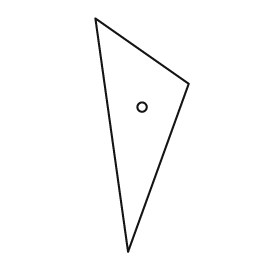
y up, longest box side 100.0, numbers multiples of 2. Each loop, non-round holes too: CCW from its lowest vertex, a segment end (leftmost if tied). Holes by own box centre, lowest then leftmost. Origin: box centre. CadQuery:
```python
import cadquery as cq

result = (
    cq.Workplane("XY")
    .moveTo(-6.0, -50.0)
    .lineTo(20.0, 22.0)
    .lineTo(-20.0, 50.0)
    .close()
    .moveTo(0.0, 12.0)
    .circle(2.0)
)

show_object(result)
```